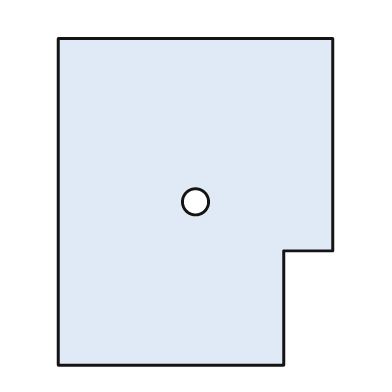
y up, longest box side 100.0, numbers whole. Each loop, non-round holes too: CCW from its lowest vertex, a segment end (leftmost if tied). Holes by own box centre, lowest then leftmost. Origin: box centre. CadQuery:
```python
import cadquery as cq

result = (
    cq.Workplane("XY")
    .moveTo(-42.0, -50.0)
    .lineTo(27.0, -50.0)
    .lineTo(27.0, -15.0)
    .lineTo(42.0, -15.0)
    .lineTo(42.0, 50.0)
    .lineTo(-42.0, 50.0)
    .close()
    .moveTo(0.0, 0.0)
    .circle(4.0)
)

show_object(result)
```